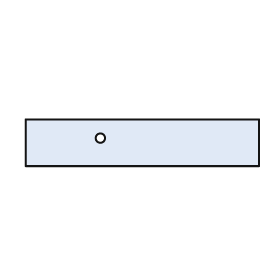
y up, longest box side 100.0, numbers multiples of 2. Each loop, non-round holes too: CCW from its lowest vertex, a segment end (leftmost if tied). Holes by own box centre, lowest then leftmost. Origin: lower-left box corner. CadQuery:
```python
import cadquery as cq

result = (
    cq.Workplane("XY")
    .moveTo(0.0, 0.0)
    .lineTo(100.0, 0.0)
    .lineTo(100.0, 20.0)
    .lineTo(0.0, 20.0)
    .close()
    .moveTo(32.0, 12.0)
    .circle(2.0)
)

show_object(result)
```